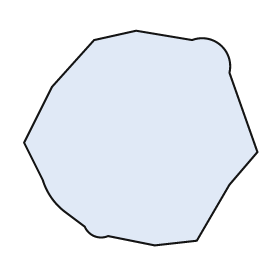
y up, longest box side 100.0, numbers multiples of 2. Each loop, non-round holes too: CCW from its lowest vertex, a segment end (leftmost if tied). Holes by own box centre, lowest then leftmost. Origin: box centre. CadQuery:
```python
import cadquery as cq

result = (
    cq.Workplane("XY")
    .moveTo(6.0, -46.0)
    .lineTo(24.0, -44.0)
    .lineTo(38.0, -20.0)
    .lineTo(50.0, -6.0)
    .lineTo(38.0, 28.0)
    .threePointArc((34.0, 40.0), (22.0, 42.0))
    .lineTo(-2.0, 46.0)
    .lineTo(-20.0, 42.0)
    .lineTo(-38.0, 22.0)
    .lineTo(-50.0, -2.0)
    .lineTo(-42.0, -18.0)
    .threePointArc((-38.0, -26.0), (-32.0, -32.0))
    .lineTo(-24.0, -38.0)
    .threePointArc((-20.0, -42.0), (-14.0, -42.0))
    .close()
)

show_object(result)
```